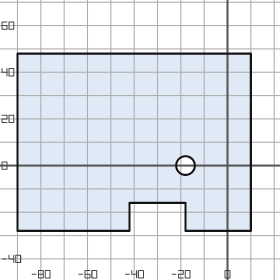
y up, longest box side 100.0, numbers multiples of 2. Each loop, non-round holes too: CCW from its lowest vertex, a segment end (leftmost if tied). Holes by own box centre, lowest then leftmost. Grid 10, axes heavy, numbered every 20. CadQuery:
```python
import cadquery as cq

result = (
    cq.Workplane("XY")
    .moveTo(-90.0, -28.0)
    .lineTo(-42.0, -28.0)
    .lineTo(-42.0, -16.0)
    .lineTo(-18.0, -16.0)
    .lineTo(-18.0, -28.0)
    .lineTo(10.0, -28.0)
    .lineTo(10.0, 48.0)
    .lineTo(-90.0, 48.0)
    .close()
    .moveTo(-18.0, 0.0)
    .circle(4.0)
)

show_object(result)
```